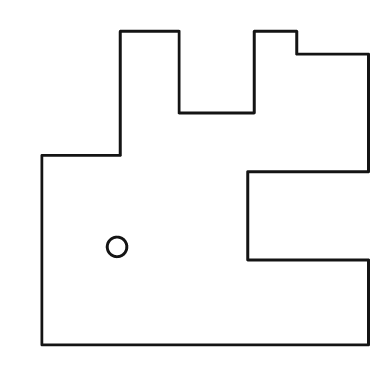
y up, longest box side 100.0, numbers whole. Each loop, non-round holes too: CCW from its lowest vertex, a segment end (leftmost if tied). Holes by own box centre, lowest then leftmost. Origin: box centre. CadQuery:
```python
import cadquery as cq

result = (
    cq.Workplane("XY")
    .moveTo(-50.0, -48.0)
    .lineTo(50.0, -48.0)
    .lineTo(50.0, -22.0)
    .lineTo(13.0, -22.0)
    .lineTo(13.0, 5.0)
    .lineTo(50.0, 5.0)
    .lineTo(50.0, 41.0)
    .lineTo(28.0, 41.0)
    .lineTo(28.0, 48.0)
    .lineTo(15.0, 48.0)
    .lineTo(15.0, 23.0)
    .lineTo(-8.0, 23.0)
    .lineTo(-8.0, 48.0)
    .lineTo(-26.0, 48.0)
    .lineTo(-26.0, 10.0)
    .lineTo(-50.0, 10.0)
    .close()
    .moveTo(-27.0, -18.0)
    .circle(3.0)
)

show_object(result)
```